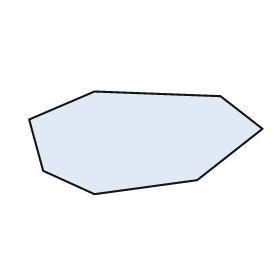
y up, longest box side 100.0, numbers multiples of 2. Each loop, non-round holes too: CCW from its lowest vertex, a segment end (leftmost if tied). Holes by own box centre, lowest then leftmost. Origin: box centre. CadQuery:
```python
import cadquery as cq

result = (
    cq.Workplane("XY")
    .moveTo(-22.0, -22.0)
    .lineTo(22.0, -16.0)
    .lineTo(50.0, 6.0)
    .lineTo(32.0, 20.0)
    .lineTo(-22.0, 22.0)
    .lineTo(-50.0, 10.0)
    .lineTo(-44.0, -12.0)
    .close()
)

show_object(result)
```